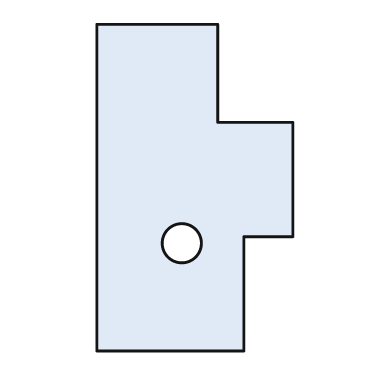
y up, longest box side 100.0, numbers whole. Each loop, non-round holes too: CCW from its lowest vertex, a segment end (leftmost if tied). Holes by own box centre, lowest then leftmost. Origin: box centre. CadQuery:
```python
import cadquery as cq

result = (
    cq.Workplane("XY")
    .moveTo(-30.0, -50.0)
    .lineTo(15.0, -50.0)
    .lineTo(15.0, -15.0)
    .lineTo(30.0, -15.0)
    .lineTo(30.0, 20.0)
    .lineTo(7.0, 20.0)
    .lineTo(7.0, 50.0)
    .lineTo(-30.0, 50.0)
    .close()
    .moveTo(-4.0, -17.0)
    .circle(6.0)
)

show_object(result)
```